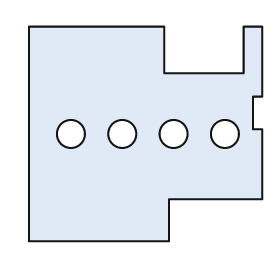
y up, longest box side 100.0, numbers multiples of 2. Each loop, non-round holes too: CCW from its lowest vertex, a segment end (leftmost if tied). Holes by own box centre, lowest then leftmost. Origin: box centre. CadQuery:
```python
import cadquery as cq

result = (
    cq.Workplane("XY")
    .moveTo(-50.0, -46.0)
    .lineTo(10.0, -46.0)
    .lineTo(10.0, -28.0)
    .lineTo(50.0, -28.0)
    .lineTo(50.0, 2.0)
    .lineTo(46.0, 2.0)
    .lineTo(46.0, 16.0)
    .lineTo(50.0, 16.0)
    .lineTo(50.0, 46.0)
    .lineTo(42.0, 46.0)
    .lineTo(42.0, 26.0)
    .lineTo(8.0, 26.0)
    .lineTo(8.0, 46.0)
    .lineTo(-50.0, 46.0)
    .close()
    .moveTo(-32.0, 0.0)
    .circle(6.0)
    .moveTo(-10.0, 0.0)
    .circle(6.0)
    .moveTo(12.0, 0.0)
    .circle(6.0)
    .moveTo(34.0, 0.0)
    .circle(6.0)
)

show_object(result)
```